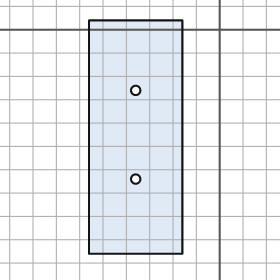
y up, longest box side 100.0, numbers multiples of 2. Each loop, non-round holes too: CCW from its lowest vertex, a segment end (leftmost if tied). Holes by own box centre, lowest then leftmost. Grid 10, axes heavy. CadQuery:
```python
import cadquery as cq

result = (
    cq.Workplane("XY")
    .moveTo(-56.0, -96.0)
    .lineTo(-16.0, -96.0)
    .lineTo(-16.0, 4.0)
    .lineTo(-56.0, 4.0)
    .close()
    .moveTo(-36.0, -64.0)
    .circle(2.0)
    .moveTo(-36.0, -26.0)
    .circle(2.0)
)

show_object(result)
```